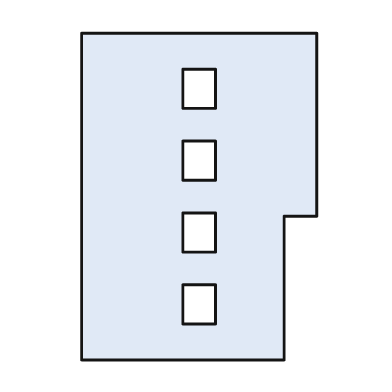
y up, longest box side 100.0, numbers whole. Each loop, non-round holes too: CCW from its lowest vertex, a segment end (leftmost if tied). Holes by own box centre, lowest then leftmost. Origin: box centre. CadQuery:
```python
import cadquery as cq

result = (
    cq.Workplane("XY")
    .moveTo(-36.0, -50.0)
    .lineTo(26.0, -50.0)
    .lineTo(26.0, -6.0)
    .lineTo(36.0, -6.0)
    .lineTo(36.0, 50.0)
    .lineTo(-36.0, 50.0)
    .close()
    .moveTo(-5.0, -39.0)
    .lineTo(5.0, -39.0)
    .lineTo(5.0, -27.0)
    .lineTo(-5.0, -27.0)
    .close()
    .moveTo(-5.0, -17.0)
    .lineTo(5.0, -17.0)
    .lineTo(5.0, -5.0)
    .lineTo(-5.0, -5.0)
    .close()
    .moveTo(-5.0, 5.0)
    .lineTo(5.0, 5.0)
    .lineTo(5.0, 17.0)
    .lineTo(-5.0, 17.0)
    .close()
    .moveTo(-5.0, 27.0)
    .lineTo(5.0, 27.0)
    .lineTo(5.0, 39.0)
    .lineTo(-5.0, 39.0)
    .close()
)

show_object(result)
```